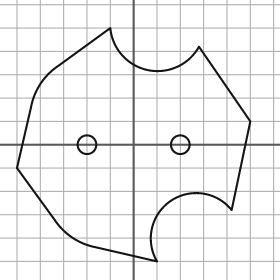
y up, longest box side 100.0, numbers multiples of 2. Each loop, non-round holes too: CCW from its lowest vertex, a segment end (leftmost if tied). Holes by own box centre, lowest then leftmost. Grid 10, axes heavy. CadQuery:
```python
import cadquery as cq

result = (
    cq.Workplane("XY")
    .moveTo(10.0, -50.0)
    .threePointArc((16.0, -24.0), (42.0, -28.0))
    .lineTo(50.0, 10.0)
    .lineTo(28.0, 42.0)
    .threePointArc((6.0, 32.0), (-10.0, 50.0))
    .lineTo(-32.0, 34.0)
    .threePointArc((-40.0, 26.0), (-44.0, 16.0))
    .lineTo(-50.0, -10.0)
    .lineTo(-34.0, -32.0)
    .threePointArc((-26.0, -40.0), (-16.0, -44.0))
    .close()
    .moveTo(-20.0, 0.0)
    .circle(4.0)
    .moveTo(20.0, 0.0)
    .circle(4.0)
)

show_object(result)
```